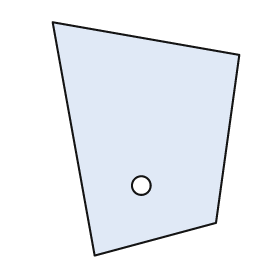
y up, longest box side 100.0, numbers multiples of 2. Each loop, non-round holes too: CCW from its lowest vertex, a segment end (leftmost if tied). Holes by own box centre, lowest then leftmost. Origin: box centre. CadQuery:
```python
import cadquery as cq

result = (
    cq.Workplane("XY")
    .moveTo(-22.0, -50.0)
    .lineTo(30.0, -36.0)
    .lineTo(40.0, 36.0)
    .lineTo(-40.0, 50.0)
    .close()
    .moveTo(-2.0, -20.0)
    .circle(4.0)
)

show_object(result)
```